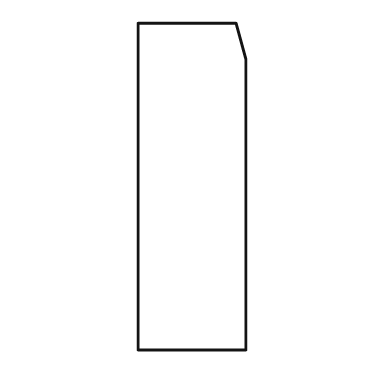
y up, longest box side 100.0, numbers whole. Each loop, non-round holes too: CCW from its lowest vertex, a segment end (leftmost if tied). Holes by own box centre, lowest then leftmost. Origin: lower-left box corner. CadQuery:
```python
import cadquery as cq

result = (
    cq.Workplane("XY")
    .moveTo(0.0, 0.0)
    .lineTo(33.0, 0.0)
    .lineTo(33.0, 89.0)
    .lineTo(30.0, 100.0)
    .lineTo(0.0, 100.0)
    .close()
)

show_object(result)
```